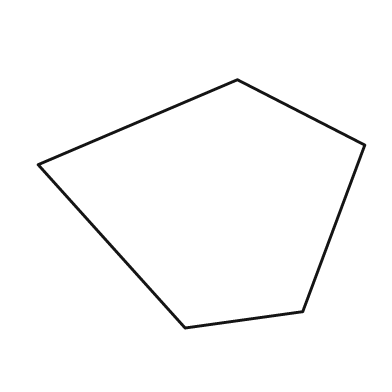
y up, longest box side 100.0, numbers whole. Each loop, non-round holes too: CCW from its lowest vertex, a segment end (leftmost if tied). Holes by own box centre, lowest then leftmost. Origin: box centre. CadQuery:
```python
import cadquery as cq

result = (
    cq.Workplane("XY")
    .moveTo(-5.0, -38.0)
    .lineTo(31.0, -33.0)
    .lineTo(50.0, 18.0)
    .lineTo(11.0, 38.0)
    .lineTo(-50.0, 12.0)
    .close()
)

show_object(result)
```